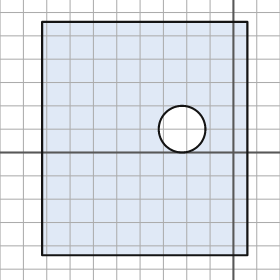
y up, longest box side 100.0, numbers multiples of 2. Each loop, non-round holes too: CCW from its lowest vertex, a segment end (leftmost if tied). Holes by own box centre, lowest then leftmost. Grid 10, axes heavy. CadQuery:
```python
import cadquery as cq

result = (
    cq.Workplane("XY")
    .moveTo(-82.0, -44.0)
    .lineTo(6.0, -44.0)
    .lineTo(6.0, 56.0)
    .lineTo(-82.0, 56.0)
    .close()
    .moveTo(-22.0, 10.0)
    .circle(10.0)
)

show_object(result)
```